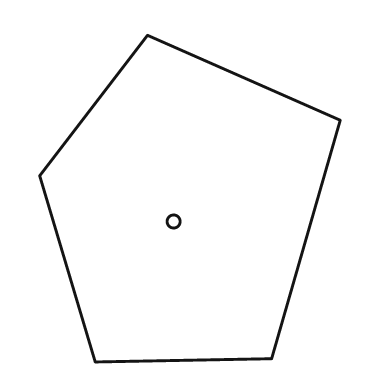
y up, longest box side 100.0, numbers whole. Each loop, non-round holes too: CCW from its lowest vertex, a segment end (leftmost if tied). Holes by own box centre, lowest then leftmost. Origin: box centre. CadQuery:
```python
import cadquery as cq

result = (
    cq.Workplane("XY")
    .moveTo(-29.0, -50.0)
    .lineTo(25.0, -49.0)
    .lineTo(46.0, 24.0)
    .lineTo(-13.0, 50.0)
    .lineTo(-46.0, 7.0)
    .close()
    .moveTo(-5.0, -7.0)
    .circle(2.0)
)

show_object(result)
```